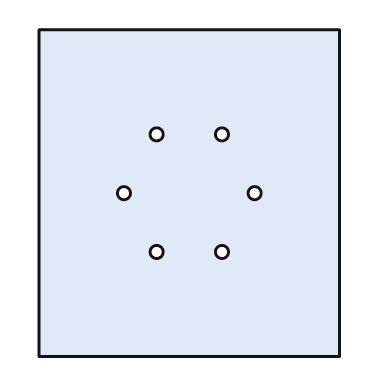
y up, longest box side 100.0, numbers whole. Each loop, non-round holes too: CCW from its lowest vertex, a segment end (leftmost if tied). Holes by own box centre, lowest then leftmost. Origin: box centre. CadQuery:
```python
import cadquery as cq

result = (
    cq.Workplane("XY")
    .moveTo(-46.0, -50.0)
    .lineTo(46.0, -50.0)
    .lineTo(46.0, 50.0)
    .lineTo(-46.0, 50.0)
    .close()
    .moveTo(-10.0, -18.0)
    .circle(2.0)
    .moveTo(10.0, -18.0)
    .circle(2.0)
    .moveTo(-20.0, 0.0)
    .circle(2.0)
    .moveTo(20.0, 0.0)
    .circle(2.0)
    .moveTo(-10.0, 18.0)
    .circle(2.0)
    .moveTo(10.0, 18.0)
    .circle(2.0)
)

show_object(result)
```